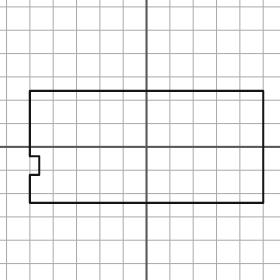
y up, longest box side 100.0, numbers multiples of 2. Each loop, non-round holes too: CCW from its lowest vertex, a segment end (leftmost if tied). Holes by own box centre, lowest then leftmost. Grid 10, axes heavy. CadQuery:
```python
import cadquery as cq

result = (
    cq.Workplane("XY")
    .moveTo(-50.0, -24.0)
    .lineTo(50.0, -24.0)
    .lineTo(50.0, 24.0)
    .lineTo(-50.0, 24.0)
    .lineTo(-50.0, -4.0)
    .lineTo(-46.0, -4.0)
    .lineTo(-46.0, -12.0)
    .lineTo(-50.0, -12.0)
    .close()
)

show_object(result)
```